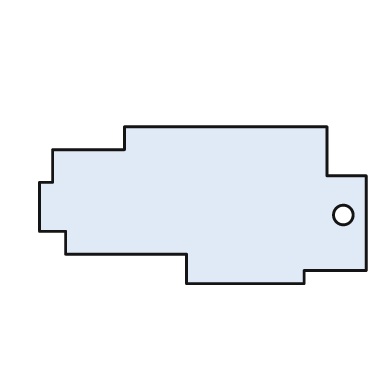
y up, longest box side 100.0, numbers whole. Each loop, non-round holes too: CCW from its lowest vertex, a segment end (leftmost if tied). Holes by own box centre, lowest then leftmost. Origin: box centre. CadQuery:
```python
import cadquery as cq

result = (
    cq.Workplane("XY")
    .moveTo(-5.0, -24.0)
    .lineTo(31.0, -24.0)
    .lineTo(31.0, -20.0)
    .lineTo(50.0, -20.0)
    .lineTo(50.0, 9.0)
    .lineTo(38.0, 9.0)
    .lineTo(38.0, 24.0)
    .lineTo(-24.0, 24.0)
    .lineTo(-24.0, 17.0)
    .lineTo(-46.0, 17.0)
    .lineTo(-46.0, 7.0)
    .lineTo(-50.0, 7.0)
    .lineTo(-50.0, -8.0)
    .lineTo(-42.0, -8.0)
    .lineTo(-42.0, -15.0)
    .lineTo(-5.0, -15.0)
    .close()
    .moveTo(43.0, -3.0)
    .circle(3.0)
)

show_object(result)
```